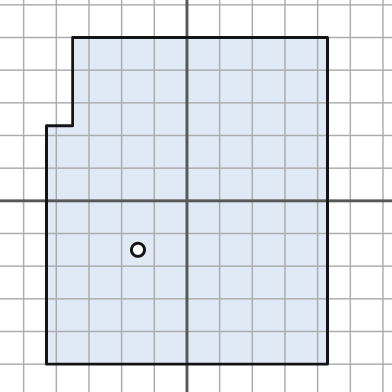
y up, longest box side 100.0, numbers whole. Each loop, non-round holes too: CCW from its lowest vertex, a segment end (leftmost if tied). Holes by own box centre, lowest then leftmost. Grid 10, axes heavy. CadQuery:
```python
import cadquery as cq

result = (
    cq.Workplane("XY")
    .moveTo(-43.0, -50.0)
    .lineTo(43.0, -50.0)
    .lineTo(43.0, 50.0)
    .lineTo(-35.0, 50.0)
    .lineTo(-35.0, 23.0)
    .lineTo(-43.0, 23.0)
    .close()
    .moveTo(-15.0, -15.0)
    .circle(2.0)
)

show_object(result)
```